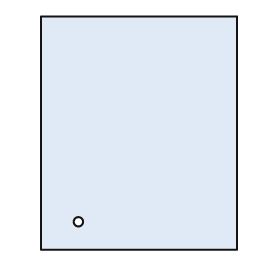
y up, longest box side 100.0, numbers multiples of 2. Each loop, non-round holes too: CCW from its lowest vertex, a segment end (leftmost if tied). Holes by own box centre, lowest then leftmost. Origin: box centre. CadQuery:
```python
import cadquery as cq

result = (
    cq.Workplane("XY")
    .moveTo(-42.0, -50.0)
    .lineTo(42.0, -50.0)
    .lineTo(42.0, 50.0)
    .lineTo(-42.0, 50.0)
    .close()
    .moveTo(-26.0, -38.0)
    .circle(2.0)
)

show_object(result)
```